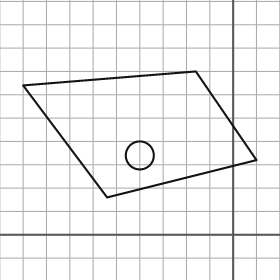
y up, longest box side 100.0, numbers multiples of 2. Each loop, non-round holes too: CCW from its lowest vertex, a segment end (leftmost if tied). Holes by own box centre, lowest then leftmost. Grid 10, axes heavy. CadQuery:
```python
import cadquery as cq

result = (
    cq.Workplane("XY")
    .moveTo(-54.0, 16.0)
    .lineTo(10.0, 32.0)
    .lineTo(-16.0, 70.0)
    .lineTo(-90.0, 64.0)
    .close()
    .moveTo(-40.0, 34.0)
    .circle(6.0)
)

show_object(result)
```